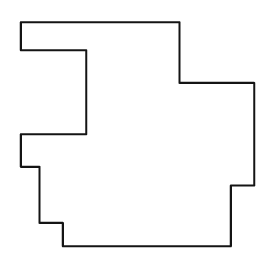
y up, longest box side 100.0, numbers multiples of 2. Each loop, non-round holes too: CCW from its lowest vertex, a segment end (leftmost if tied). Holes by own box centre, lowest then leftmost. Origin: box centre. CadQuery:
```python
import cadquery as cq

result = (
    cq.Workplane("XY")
    .moveTo(-32.0, -48.0)
    .lineTo(40.0, -48.0)
    .lineTo(40.0, -22.0)
    .lineTo(50.0, -22.0)
    .lineTo(50.0, 22.0)
    .lineTo(18.0, 22.0)
    .lineTo(18.0, 48.0)
    .lineTo(-50.0, 48.0)
    .lineTo(-50.0, 36.0)
    .lineTo(-22.0, 36.0)
    .lineTo(-22.0, 0.0)
    .lineTo(-50.0, 0.0)
    .lineTo(-50.0, -14.0)
    .lineTo(-42.0, -14.0)
    .lineTo(-42.0, -38.0)
    .lineTo(-32.0, -38.0)
    .close()
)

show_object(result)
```